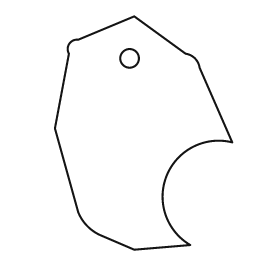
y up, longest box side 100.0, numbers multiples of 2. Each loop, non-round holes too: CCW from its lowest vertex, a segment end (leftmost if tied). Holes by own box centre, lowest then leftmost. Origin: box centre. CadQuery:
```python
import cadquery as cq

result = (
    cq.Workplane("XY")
    .moveTo(-4.0, -50.0)
    .lineTo(20.0, -48.0)
    .threePointArc((10.0, -18.0), (38.0, -4.0))
    .lineTo(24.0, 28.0)
    .threePointArc((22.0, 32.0), (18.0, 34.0))
    .lineTo(-4.0, 50.0)
    .lineTo(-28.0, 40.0)
    .threePointArc((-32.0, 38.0), (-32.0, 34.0))
    .lineTo(-38.0, 2.0)
    .lineTo(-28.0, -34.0)
    .threePointArc((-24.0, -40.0), (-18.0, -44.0))
    .close()
    .moveTo(-6.0, 32.0)
    .circle(4.0)
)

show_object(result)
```